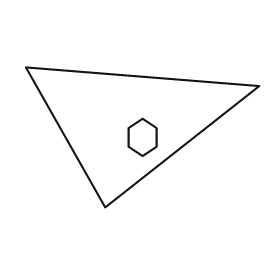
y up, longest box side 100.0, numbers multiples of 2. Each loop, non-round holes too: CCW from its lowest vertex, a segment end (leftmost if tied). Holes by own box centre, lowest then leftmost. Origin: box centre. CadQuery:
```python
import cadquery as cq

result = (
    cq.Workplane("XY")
    .moveTo(-16.0, -30.0)
    .lineTo(50.0, 22.0)
    .lineTo(-50.0, 30.0)
    .close()
    .moveTo(0.0, -8.0)
    .lineTo(6.0, -4.0)
    .lineTo(6.0, 4.0)
    .lineTo(0.0, 8.0)
    .lineTo(-6.0, 4.0)
    .lineTo(-6.0, -4.0)
    .close()
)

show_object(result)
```